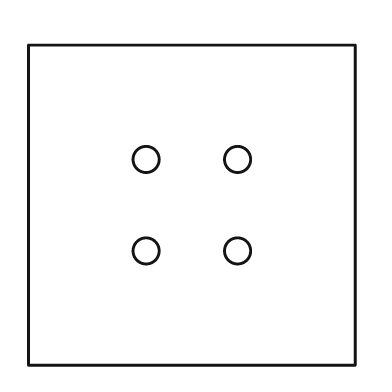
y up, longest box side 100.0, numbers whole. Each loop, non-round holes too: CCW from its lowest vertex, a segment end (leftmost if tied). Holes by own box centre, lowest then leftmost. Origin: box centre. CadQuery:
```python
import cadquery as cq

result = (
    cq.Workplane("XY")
    .moveTo(-50.0, -49.0)
    .lineTo(50.0, -49.0)
    .lineTo(50.0, 49.0)
    .lineTo(-50.0, 49.0)
    .close()
    .moveTo(-14.0, -14.0)
    .circle(4.0)
    .moveTo(14.0, -14.0)
    .circle(4.0)
    .moveTo(-14.0, 14.0)
    .circle(4.0)
    .moveTo(14.0, 14.0)
    .circle(4.0)
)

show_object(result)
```